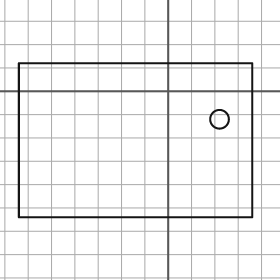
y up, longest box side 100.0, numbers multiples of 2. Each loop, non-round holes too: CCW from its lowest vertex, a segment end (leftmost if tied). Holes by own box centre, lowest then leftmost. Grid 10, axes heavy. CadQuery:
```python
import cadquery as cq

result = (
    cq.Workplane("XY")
    .moveTo(-64.0, -54.0)
    .lineTo(36.0, -54.0)
    .lineTo(36.0, 12.0)
    .lineTo(-64.0, 12.0)
    .close()
    .moveTo(22.0, -12.0)
    .circle(4.0)
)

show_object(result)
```